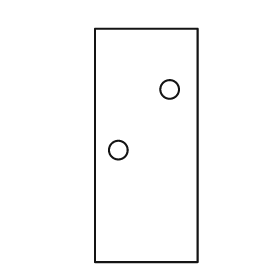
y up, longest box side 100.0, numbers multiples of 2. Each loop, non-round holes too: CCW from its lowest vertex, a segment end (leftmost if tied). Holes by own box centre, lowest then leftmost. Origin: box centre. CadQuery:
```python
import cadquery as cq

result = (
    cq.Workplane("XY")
    .moveTo(-22.0, -50.0)
    .lineTo(22.0, -50.0)
    .lineTo(22.0, 50.0)
    .lineTo(-22.0, 50.0)
    .close()
    .moveTo(-12.0, -2.0)
    .circle(4.0)
    .moveTo(10.0, 24.0)
    .circle(4.0)
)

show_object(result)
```